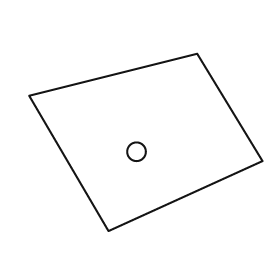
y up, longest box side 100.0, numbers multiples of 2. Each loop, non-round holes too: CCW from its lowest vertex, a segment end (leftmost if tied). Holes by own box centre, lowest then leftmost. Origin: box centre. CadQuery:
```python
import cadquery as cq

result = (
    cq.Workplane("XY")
    .moveTo(-16.0, -38.0)
    .lineTo(50.0, -8.0)
    .lineTo(22.0, 38.0)
    .lineTo(-50.0, 20.0)
    .close()
    .moveTo(-4.0, -4.0)
    .circle(4.0)
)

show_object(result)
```